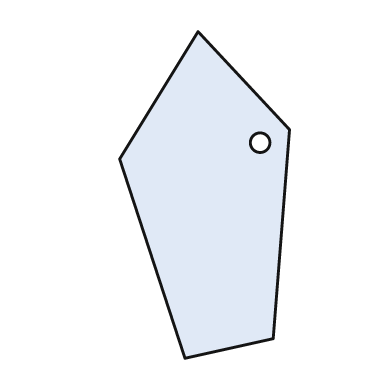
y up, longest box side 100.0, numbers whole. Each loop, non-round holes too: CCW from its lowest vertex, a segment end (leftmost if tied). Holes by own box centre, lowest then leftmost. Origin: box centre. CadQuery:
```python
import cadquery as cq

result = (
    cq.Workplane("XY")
    .moveTo(-6.0, -50.0)
    .lineTo(21.0, -44.0)
    .lineTo(26.0, 20.0)
    .lineTo(-2.0, 50.0)
    .lineTo(-26.0, 11.0)
    .close()
    .moveTo(17.0, 16.0)
    .circle(3.0)
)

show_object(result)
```